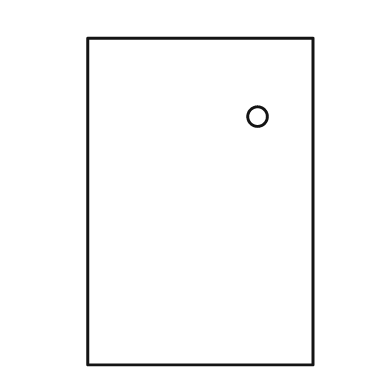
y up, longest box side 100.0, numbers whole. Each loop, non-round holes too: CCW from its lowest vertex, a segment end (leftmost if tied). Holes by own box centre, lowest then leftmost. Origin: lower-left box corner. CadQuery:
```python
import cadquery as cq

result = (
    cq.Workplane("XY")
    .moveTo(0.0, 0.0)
    .lineTo(69.0, 0.0)
    .lineTo(69.0, 100.0)
    .lineTo(0.0, 100.0)
    .close()
    .moveTo(52.0, 76.0)
    .circle(3.0)
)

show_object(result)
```